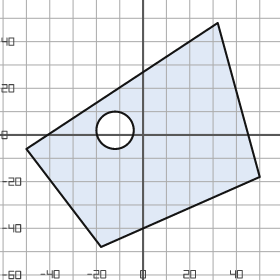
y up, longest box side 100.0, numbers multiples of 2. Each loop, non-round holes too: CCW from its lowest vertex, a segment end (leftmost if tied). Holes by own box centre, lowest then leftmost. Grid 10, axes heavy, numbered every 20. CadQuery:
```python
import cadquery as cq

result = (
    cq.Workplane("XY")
    .moveTo(-18.0, -48.0)
    .lineTo(50.0, -18.0)
    .lineTo(32.0, 48.0)
    .lineTo(-50.0, -6.0)
    .close()
    .moveTo(-12.0, 2.0)
    .circle(8.0)
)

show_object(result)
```